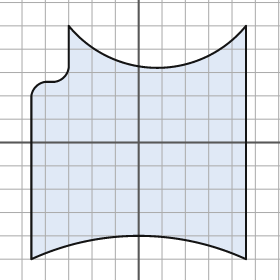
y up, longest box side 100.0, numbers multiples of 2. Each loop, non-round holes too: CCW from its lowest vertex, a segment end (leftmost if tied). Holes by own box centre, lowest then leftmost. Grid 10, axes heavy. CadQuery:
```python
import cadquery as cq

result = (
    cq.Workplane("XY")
    .moveTo(-46.0, -50.0)
    .threePointArc((0.0, -40.0), (46.0, -50.0))
    .lineTo(46.0, 50.0)
    .threePointArc((8.0, 32.0), (-30.0, 50.0))
    .lineTo(-30.0, 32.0)
    .threePointArc((-32.0, 28.0), (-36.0, 26.0))
    .lineTo(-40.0, 26.0)
    .threePointArc((-44.0, 24.0), (-46.0, 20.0))
    .close()
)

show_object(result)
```